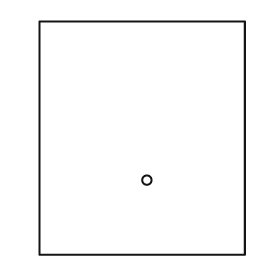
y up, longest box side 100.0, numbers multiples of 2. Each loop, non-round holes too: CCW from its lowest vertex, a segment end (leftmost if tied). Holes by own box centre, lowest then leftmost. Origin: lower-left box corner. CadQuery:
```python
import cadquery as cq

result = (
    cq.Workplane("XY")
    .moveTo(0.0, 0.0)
    .lineTo(88.0, 0.0)
    .lineTo(88.0, 100.0)
    .lineTo(0.0, 100.0)
    .close()
    .moveTo(46.0, 32.0)
    .circle(2.0)
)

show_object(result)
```